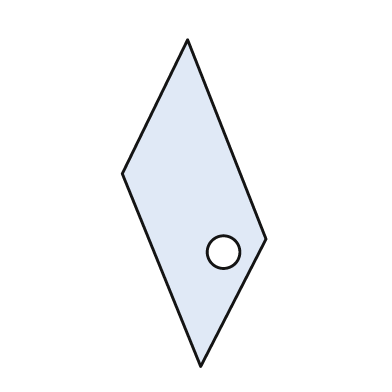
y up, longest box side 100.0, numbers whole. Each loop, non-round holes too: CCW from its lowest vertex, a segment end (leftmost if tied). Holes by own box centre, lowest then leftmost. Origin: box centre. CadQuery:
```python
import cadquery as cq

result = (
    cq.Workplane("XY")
    .moveTo(2.0, -50.0)
    .lineTo(22.0, -11.0)
    .lineTo(-2.0, 50.0)
    .lineTo(-22.0, 9.0)
    .close()
    .moveTo(9.0, -15.0)
    .circle(5.0)
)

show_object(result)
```